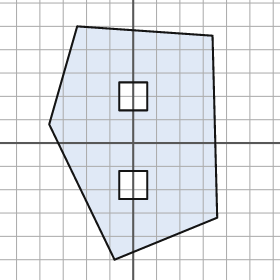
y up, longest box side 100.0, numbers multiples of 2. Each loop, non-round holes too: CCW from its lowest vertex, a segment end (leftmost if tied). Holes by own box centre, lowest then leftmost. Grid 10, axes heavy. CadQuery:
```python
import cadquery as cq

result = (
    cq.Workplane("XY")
    .moveTo(-8.0, -50.0)
    .lineTo(36.0, -32.0)
    .lineTo(34.0, 46.0)
    .lineTo(-24.0, 50.0)
    .lineTo(-36.0, 8.0)
    .close()
    .moveTo(-6.0, -24.0)
    .lineTo(6.0, -24.0)
    .lineTo(6.0, -12.0)
    .lineTo(-6.0, -12.0)
    .close()
    .moveTo(-6.0, 14.0)
    .lineTo(6.0, 14.0)
    .lineTo(6.0, 26.0)
    .lineTo(-6.0, 26.0)
    .close()
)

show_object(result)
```